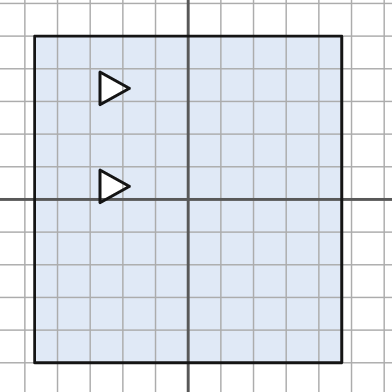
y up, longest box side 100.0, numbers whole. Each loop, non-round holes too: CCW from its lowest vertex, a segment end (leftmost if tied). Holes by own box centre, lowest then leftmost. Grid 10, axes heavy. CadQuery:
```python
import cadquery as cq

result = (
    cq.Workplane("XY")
    .moveTo(-47.0, -50.0)
    .lineTo(47.0, -50.0)
    .lineTo(47.0, 50.0)
    .lineTo(-47.0, 50.0)
    .close()
    .moveTo(-27.0, -1.0)
    .lineTo(-18.0, 4.0)
    .lineTo(-27.0, 9.0)
    .close()
    .moveTo(-27.0, 29.0)
    .lineTo(-18.0, 34.0)
    .lineTo(-27.0, 39.0)
    .close()
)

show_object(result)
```